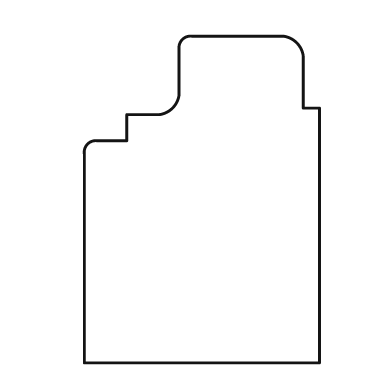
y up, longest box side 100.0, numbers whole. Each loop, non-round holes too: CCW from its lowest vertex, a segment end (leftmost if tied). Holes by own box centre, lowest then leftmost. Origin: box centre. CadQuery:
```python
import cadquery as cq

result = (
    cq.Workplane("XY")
    .moveTo(-36.0, -50.0)
    .lineTo(36.0, -50.0)
    .lineTo(36.0, 28.0)
    .lineTo(31.0, 28.0)
    .lineTo(31.0, 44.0)
    .threePointArc((29.0, 48.0), (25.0, 50.0))
    .lineTo(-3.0, 50.0)
    .threePointArc((-6.0, 49.0), (-7.0, 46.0))
    .lineTo(-7.0, 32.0)
    .threePointArc((-9.0, 28.0), (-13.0, 26.0))
    .lineTo(-23.0, 26.0)
    .lineTo(-23.0, 18.0)
    .lineTo(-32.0, 18.0)
    .threePointArc((-35.0, 17.0), (-36.0, 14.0))
    .close()
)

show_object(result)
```